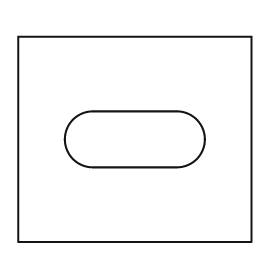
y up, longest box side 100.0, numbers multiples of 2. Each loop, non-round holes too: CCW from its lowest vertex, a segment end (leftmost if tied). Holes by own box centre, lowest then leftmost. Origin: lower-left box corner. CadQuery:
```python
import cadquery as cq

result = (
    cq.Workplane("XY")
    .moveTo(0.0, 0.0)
    .lineTo(100.0, 0.0)
    .lineTo(100.0, 88.0)
    .lineTo(0.0, 88.0)
    .close()
    .moveTo(32.0, 32.0)
    .lineTo(68.0, 32.0)
    .threePointArc((80.0, 44.0), (68.0, 56.0))
    .lineTo(32.0, 56.0)
    .threePointArc((20.0, 44.0), (32.0, 32.0))
    .close()
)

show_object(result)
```